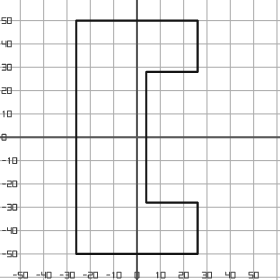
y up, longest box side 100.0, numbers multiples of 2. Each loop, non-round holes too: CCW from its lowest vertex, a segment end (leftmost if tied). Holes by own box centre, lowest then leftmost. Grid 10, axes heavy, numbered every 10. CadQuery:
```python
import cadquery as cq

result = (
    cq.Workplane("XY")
    .moveTo(-26.0, -50.0)
    .lineTo(26.0, -50.0)
    .lineTo(26.0, -28.0)
    .lineTo(4.0, -28.0)
    .lineTo(4.0, 28.0)
    .lineTo(26.0, 28.0)
    .lineTo(26.0, 50.0)
    .lineTo(-26.0, 50.0)
    .close()
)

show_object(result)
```